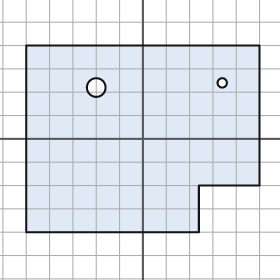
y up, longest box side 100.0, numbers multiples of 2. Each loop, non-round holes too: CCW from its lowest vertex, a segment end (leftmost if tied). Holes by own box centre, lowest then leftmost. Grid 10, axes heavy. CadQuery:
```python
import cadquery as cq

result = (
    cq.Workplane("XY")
    .moveTo(-50.0, -40.0)
    .lineTo(24.0, -40.0)
    .lineTo(24.0, -20.0)
    .lineTo(50.0, -20.0)
    .lineTo(50.0, 40.0)
    .lineTo(-50.0, 40.0)
    .close()
    .moveTo(-20.0, 22.0)
    .circle(4.0)
    .moveTo(34.0, 24.0)
    .circle(2.0)
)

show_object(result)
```